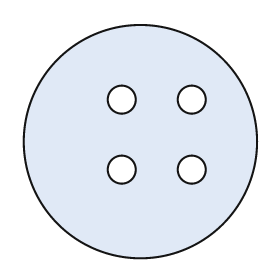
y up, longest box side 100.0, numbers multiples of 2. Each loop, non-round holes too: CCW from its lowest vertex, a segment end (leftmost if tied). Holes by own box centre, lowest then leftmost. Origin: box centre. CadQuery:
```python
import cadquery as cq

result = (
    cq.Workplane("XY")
    .moveTo(0.0, 0.0)
    .circle(50.0)
    .moveTo(-8.0, -12.0)
    .circle(6.0)
    .moveTo(22.0, -12.0)
    .circle(6.0)
    .moveTo(-8.0, 18.0)
    .circle(6.0)
    .moveTo(22.0, 18.0)
    .circle(6.0)
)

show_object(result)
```